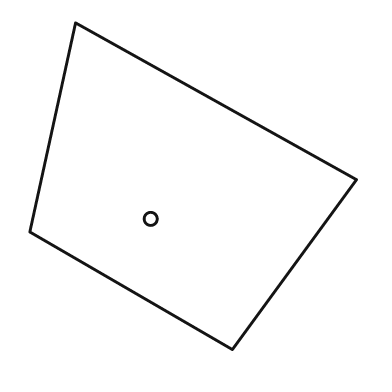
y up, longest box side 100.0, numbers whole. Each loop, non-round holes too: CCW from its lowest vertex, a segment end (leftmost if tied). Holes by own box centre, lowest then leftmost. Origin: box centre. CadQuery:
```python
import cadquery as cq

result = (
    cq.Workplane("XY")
    .moveTo(12.0, -50.0)
    .lineTo(50.0, 2.0)
    .lineTo(-36.0, 50.0)
    .lineTo(-50.0, -14.0)
    .close()
    .moveTo(-13.0, -10.0)
    .circle(2.0)
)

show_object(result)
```